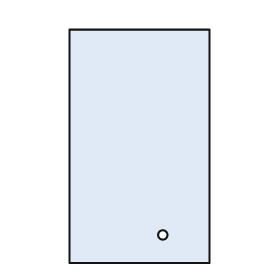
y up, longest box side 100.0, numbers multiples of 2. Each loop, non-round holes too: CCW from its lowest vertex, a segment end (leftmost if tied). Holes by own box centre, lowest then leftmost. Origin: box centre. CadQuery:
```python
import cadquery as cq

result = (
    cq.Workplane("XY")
    .moveTo(-30.0, -50.0)
    .lineTo(30.0, -50.0)
    .lineTo(30.0, 50.0)
    .lineTo(-30.0, 50.0)
    .close()
    .moveTo(10.0, -38.0)
    .circle(2.0)
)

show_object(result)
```